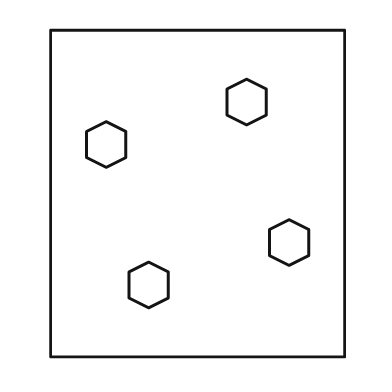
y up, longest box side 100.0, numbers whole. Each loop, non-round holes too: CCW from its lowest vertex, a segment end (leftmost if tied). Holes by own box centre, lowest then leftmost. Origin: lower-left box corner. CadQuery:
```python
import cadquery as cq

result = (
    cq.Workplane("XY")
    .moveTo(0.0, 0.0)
    .lineTo(90.0, 0.0)
    .lineTo(90.0, 100.0)
    .lineTo(0.0, 100.0)
    .close()
    .moveTo(30.0, 15.0)
    .lineTo(36.0, 18.0)
    .lineTo(36.0, 26.0)
    .lineTo(30.0, 29.0)
    .lineTo(24.0, 26.0)
    .lineTo(24.0, 18.0)
    .close()
    .moveTo(73.0, 28.0)
    .lineTo(79.0, 31.0)
    .lineTo(79.0, 39.0)
    .lineTo(73.0, 42.0)
    .lineTo(67.0, 39.0)
    .lineTo(67.0, 31.0)
    .close()
    .moveTo(17.0, 58.0)
    .lineTo(23.0, 61.0)
    .lineTo(23.0, 69.0)
    .lineTo(17.0, 72.0)
    .lineTo(11.0, 69.0)
    .lineTo(11.0, 61.0)
    .close()
    .moveTo(60.0, 71.0)
    .lineTo(66.0, 74.0)
    .lineTo(66.0, 82.0)
    .lineTo(60.0, 85.0)
    .lineTo(54.0, 82.0)
    .lineTo(54.0, 74.0)
    .close()
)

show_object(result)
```